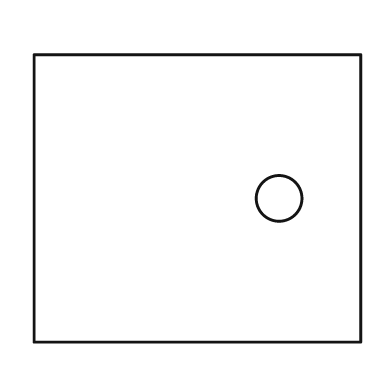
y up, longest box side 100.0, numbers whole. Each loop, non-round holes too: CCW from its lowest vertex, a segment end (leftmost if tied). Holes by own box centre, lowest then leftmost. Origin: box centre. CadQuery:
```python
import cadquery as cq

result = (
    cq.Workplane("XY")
    .moveTo(-50.0, -44.0)
    .lineTo(50.0, -44.0)
    .lineTo(50.0, 44.0)
    .lineTo(-50.0, 44.0)
    .close()
    .moveTo(25.0, 0.0)
    .circle(7.0)
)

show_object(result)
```